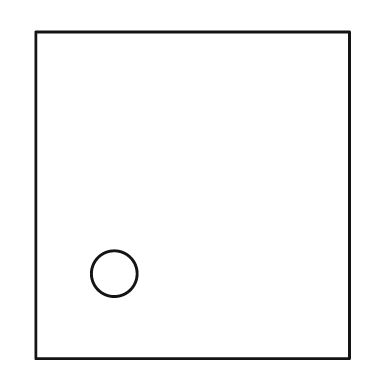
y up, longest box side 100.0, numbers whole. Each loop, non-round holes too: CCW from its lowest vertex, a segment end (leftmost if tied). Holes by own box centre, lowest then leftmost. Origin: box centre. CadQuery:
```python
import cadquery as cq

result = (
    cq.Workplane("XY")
    .moveTo(-48.0, -50.0)
    .lineTo(48.0, -50.0)
    .lineTo(48.0, 50.0)
    .lineTo(-48.0, 50.0)
    .close()
    .moveTo(-24.0, -24.0)
    .circle(7.0)
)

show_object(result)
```